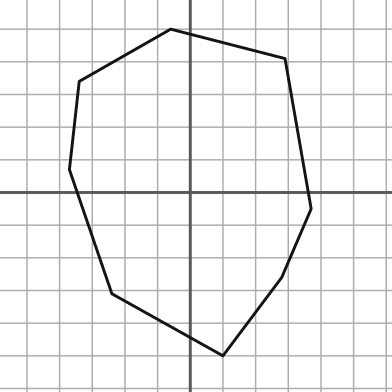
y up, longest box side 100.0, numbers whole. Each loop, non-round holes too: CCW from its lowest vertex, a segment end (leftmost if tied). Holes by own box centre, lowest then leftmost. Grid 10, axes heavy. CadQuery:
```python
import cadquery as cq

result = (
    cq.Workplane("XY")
    .moveTo(10.0, -50.0)
    .lineTo(28.0, -26.0)
    .lineTo(37.0, -5.0)
    .lineTo(29.0, 41.0)
    .lineTo(-6.0, 50.0)
    .lineTo(-34.0, 34.0)
    .lineTo(-37.0, 7.0)
    .lineTo(-24.0, -31.0)
    .close()
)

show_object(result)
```